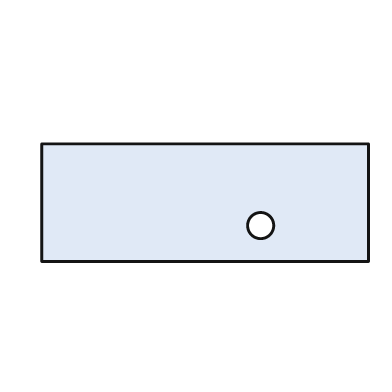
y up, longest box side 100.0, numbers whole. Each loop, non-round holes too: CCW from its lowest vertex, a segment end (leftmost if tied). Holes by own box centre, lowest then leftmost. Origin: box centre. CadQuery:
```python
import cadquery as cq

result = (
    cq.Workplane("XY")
    .moveTo(-50.0, -18.0)
    .lineTo(50.0, -18.0)
    .lineTo(50.0, 18.0)
    .lineTo(-50.0, 18.0)
    .close()
    .moveTo(17.0, -7.0)
    .circle(4.0)
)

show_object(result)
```